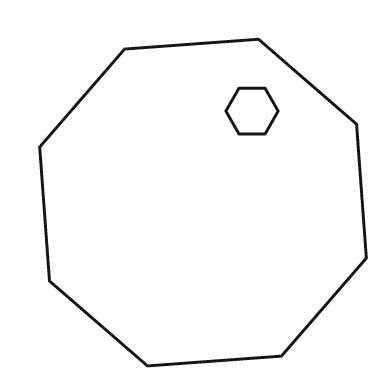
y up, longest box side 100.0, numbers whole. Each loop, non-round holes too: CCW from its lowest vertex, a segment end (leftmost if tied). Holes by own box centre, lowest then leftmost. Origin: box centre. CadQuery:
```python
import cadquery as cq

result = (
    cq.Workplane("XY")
    .moveTo(-17.0, -50.0)
    .lineTo(24.0, -47.0)
    .lineTo(50.0, -17.0)
    .lineTo(47.0, 24.0)
    .lineTo(17.0, 50.0)
    .lineTo(-24.0, 47.0)
    .lineTo(-50.0, 17.0)
    .lineTo(-47.0, -24.0)
    .close()
    .moveTo(11.0, 21.0)
    .lineTo(19.0, 21.0)
    .lineTo(23.0, 28.0)
    .lineTo(19.0, 35.0)
    .lineTo(11.0, 35.0)
    .lineTo(7.0, 28.0)
    .close()
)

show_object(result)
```